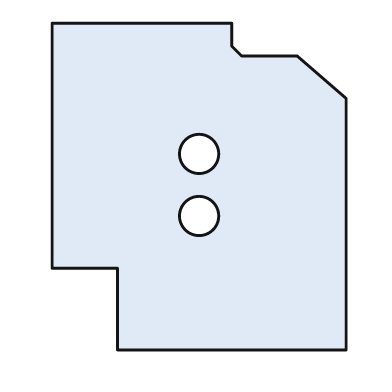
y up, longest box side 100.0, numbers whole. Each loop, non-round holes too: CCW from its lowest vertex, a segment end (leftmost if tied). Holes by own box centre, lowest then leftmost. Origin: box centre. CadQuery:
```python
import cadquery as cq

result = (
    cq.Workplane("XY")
    .moveTo(-25.0, -50.0)
    .lineTo(45.0, -50.0)
    .lineTo(45.0, 27.0)
    .lineTo(30.0, 40.0)
    .lineTo(13.0, 40.0)
    .lineTo(10.0, 43.0)
    .lineTo(10.0, 50.0)
    .lineTo(-45.0, 50.0)
    .lineTo(-45.0, -25.0)
    .lineTo(-25.0, -25.0)
    .close()
    .moveTo(0.0, -9.0)
    .circle(6.0)
    .moveTo(0.0, 10.0)
    .circle(6.0)
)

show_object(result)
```